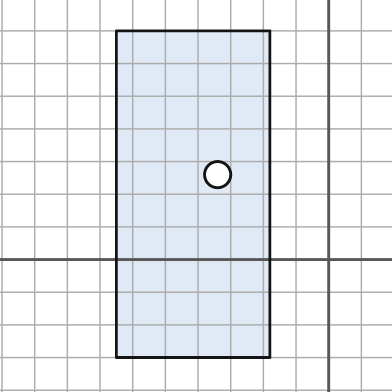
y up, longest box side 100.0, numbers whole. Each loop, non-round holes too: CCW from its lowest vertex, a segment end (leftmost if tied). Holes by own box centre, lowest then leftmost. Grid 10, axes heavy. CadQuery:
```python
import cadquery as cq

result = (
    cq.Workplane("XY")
    .moveTo(-65.0, -30.0)
    .lineTo(-18.0, -30.0)
    .lineTo(-18.0, 70.0)
    .lineTo(-65.0, 70.0)
    .close()
    .moveTo(-34.0, 26.0)
    .circle(4.0)
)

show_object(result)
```